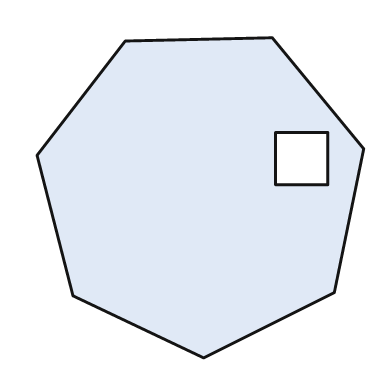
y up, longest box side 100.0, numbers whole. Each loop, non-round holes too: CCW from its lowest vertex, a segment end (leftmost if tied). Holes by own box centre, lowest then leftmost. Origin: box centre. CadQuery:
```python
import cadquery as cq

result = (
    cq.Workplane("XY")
    .moveTo(1.0, -49.0)
    .lineTo(41.0, -29.0)
    .lineTo(50.0, 15.0)
    .lineTo(22.0, 49.0)
    .lineTo(-23.0, 48.0)
    .lineTo(-50.0, 13.0)
    .lineTo(-39.0, -30.0)
    .close()
    .moveTo(23.0, 4.0)
    .lineTo(39.0, 4.0)
    .lineTo(39.0, 20.0)
    .lineTo(23.0, 20.0)
    .close()
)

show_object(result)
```